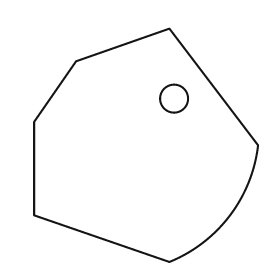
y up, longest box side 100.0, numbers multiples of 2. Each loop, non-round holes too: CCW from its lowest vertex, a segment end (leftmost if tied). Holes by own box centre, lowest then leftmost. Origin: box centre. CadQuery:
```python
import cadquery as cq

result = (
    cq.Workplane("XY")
    .moveTo(10.0, -50.0)
    .threePointArc((36.0, -30.0), (48.0, 0.0))
    .lineTo(10.0, 50.0)
    .lineTo(-30.0, 36.0)
    .lineTo(-48.0, 10.0)
    .lineTo(-48.0, -30.0)
    .close()
    .moveTo(12.0, 20.0)
    .circle(6.0)
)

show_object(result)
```